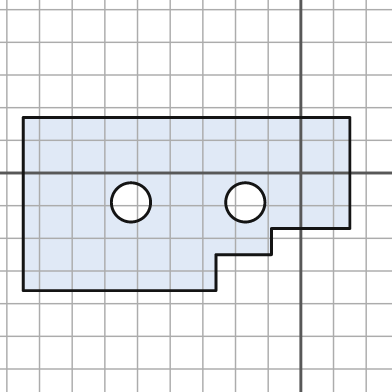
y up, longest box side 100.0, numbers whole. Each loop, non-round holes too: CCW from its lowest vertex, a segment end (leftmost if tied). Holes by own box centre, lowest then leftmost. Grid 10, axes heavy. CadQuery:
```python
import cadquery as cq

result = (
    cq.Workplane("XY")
    .moveTo(-85.0, -36.0)
    .lineTo(-26.0, -36.0)
    .lineTo(-26.0, -25.0)
    .lineTo(-9.0, -25.0)
    .lineTo(-9.0, -17.0)
    .lineTo(15.0, -17.0)
    .lineTo(15.0, 17.0)
    .lineTo(-85.0, 17.0)
    .close()
    .moveTo(-52.0, -9.0)
    .circle(6.0)
    .moveTo(-17.0, -9.0)
    .circle(6.0)
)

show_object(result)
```